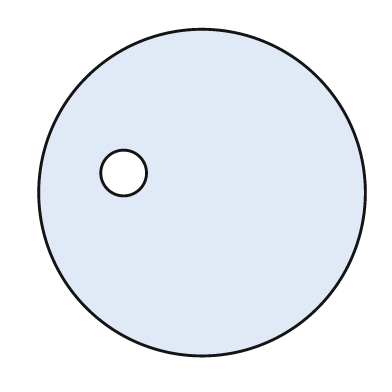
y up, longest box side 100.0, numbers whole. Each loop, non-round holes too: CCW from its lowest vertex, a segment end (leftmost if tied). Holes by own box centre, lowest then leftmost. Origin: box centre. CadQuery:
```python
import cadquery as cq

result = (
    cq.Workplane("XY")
    .moveTo(0.0, 0.0)
    .circle(50.0)
    .moveTo(-24.0, 6.0)
    .circle(7.0)
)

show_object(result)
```